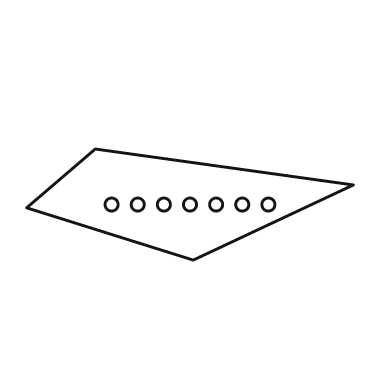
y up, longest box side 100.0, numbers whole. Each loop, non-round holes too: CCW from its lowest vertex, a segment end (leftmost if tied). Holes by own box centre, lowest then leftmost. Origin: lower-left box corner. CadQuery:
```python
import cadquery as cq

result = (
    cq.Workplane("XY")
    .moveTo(51.0, 0.0)
    .lineTo(100.0, 23.0)
    .lineTo(21.0, 34.0)
    .lineTo(0.0, 16.0)
    .close()
    .moveTo(26.0, 17.0)
    .circle(2.0)
    .moveTo(34.0, 17.0)
    .circle(2.0)
    .moveTo(42.0, 17.0)
    .circle(2.0)
    .moveTo(50.0, 17.0)
    .circle(2.0)
    .moveTo(58.0, 17.0)
    .circle(2.0)
    .moveTo(66.0, 17.0)
    .circle(2.0)
    .moveTo(74.0, 17.0)
    .circle(2.0)
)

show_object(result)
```